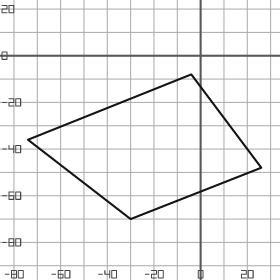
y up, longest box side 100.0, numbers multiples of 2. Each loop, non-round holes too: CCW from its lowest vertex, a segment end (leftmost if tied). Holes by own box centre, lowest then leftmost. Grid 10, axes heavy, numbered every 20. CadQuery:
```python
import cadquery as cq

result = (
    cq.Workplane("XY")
    .moveTo(-30.0, -70.0)
    .lineTo(26.0, -48.0)
    .lineTo(-4.0, -8.0)
    .lineTo(-74.0, -36.0)
    .close()
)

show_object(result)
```